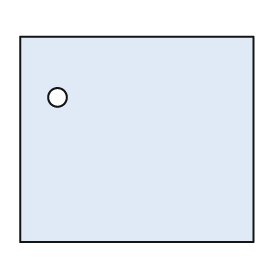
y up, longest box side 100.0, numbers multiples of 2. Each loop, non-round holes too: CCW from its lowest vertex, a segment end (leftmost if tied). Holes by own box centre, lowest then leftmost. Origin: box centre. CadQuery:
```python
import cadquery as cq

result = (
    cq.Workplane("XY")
    .moveTo(-50.0, -44.0)
    .lineTo(50.0, -44.0)
    .lineTo(50.0, 44.0)
    .lineTo(-50.0, 44.0)
    .close()
    .moveTo(-34.0, 18.0)
    .circle(4.0)
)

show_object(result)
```